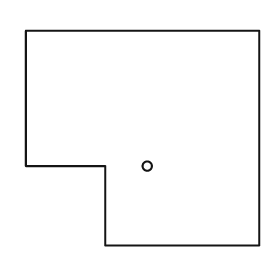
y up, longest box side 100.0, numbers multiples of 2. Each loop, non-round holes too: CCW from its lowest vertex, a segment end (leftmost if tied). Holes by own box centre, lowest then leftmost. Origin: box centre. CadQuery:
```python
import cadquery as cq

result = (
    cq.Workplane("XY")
    .moveTo(-16.0, -46.0)
    .lineTo(50.0, -46.0)
    .lineTo(50.0, 46.0)
    .lineTo(-50.0, 46.0)
    .lineTo(-50.0, -12.0)
    .lineTo(-16.0, -12.0)
    .close()
    .moveTo(2.0, -12.0)
    .circle(2.0)
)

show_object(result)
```